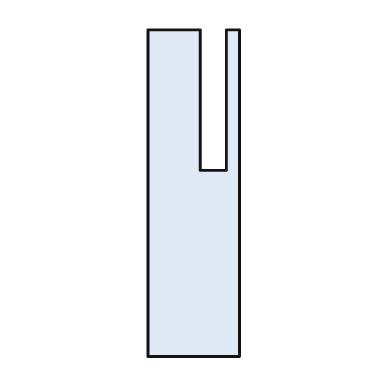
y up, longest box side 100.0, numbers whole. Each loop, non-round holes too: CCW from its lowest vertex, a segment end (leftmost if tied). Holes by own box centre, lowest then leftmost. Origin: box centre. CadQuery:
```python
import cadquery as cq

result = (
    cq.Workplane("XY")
    .moveTo(-14.0, -50.0)
    .lineTo(14.0, -50.0)
    .lineTo(14.0, 50.0)
    .lineTo(10.0, 50.0)
    .lineTo(10.0, 7.0)
    .lineTo(2.0, 7.0)
    .lineTo(2.0, 50.0)
    .lineTo(-14.0, 50.0)
    .close()
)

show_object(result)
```